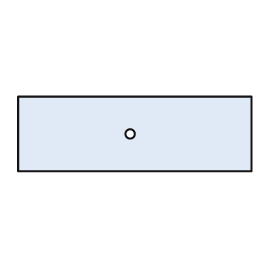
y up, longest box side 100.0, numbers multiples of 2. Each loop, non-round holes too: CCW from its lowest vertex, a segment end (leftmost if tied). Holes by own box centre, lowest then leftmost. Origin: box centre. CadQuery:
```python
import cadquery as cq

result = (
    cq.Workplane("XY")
    .moveTo(-50.0, -16.0)
    .lineTo(50.0, -16.0)
    .lineTo(50.0, 16.0)
    .lineTo(-50.0, 16.0)
    .close()
    .moveTo(-2.0, 0.0)
    .circle(2.0)
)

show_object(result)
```